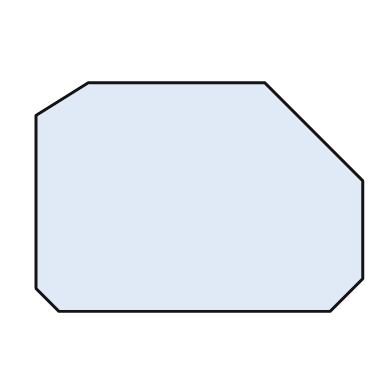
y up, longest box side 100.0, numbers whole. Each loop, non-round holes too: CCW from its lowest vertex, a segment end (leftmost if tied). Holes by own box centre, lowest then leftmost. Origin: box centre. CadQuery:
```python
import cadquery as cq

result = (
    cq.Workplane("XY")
    .moveTo(-43.0, -35.0)
    .lineTo(40.0, -35.0)
    .lineTo(50.0, -25.0)
    .lineTo(50.0, 5.0)
    .lineTo(20.0, 35.0)
    .lineTo(-34.0, 35.0)
    .lineTo(-50.0, 25.0)
    .lineTo(-50.0, -28.0)
    .close()
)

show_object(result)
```